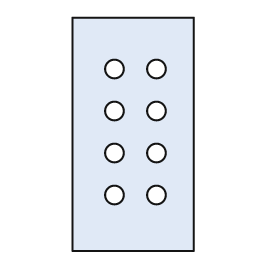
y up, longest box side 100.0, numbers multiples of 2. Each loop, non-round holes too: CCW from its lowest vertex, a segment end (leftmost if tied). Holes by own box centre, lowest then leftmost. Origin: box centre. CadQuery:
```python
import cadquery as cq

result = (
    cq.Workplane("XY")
    .moveTo(-26.0, -50.0)
    .lineTo(26.0, -50.0)
    .lineTo(26.0, 50.0)
    .lineTo(-26.0, 50.0)
    .close()
    .moveTo(-8.0, -26.0)
    .circle(4.0)
    .moveTo(10.0, -26.0)
    .circle(4.0)
    .moveTo(-8.0, -8.0)
    .circle(4.0)
    .moveTo(10.0, -8.0)
    .circle(4.0)
    .moveTo(-8.0, 10.0)
    .circle(4.0)
    .moveTo(10.0, 10.0)
    .circle(4.0)
    .moveTo(-8.0, 28.0)
    .circle(4.0)
    .moveTo(10.0, 28.0)
    .circle(4.0)
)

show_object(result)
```